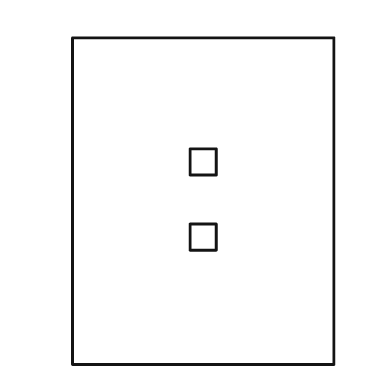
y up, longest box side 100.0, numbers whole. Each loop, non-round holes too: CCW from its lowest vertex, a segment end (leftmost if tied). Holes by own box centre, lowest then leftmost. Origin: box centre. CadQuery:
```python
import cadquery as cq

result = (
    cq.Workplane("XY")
    .moveTo(-40.0, -50.0)
    .lineTo(40.0, -50.0)
    .lineTo(40.0, 50.0)
    .lineTo(-40.0, 50.0)
    .close()
    .moveTo(-4.0, -15.0)
    .lineTo(4.0, -15.0)
    .lineTo(4.0, -7.0)
    .lineTo(-4.0, -7.0)
    .close()
    .moveTo(-4.0, 8.0)
    .lineTo(4.0, 8.0)
    .lineTo(4.0, 16.0)
    .lineTo(-4.0, 16.0)
    .close()
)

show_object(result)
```